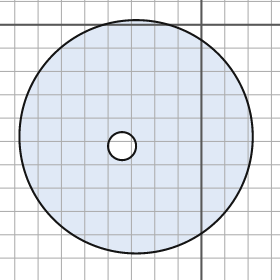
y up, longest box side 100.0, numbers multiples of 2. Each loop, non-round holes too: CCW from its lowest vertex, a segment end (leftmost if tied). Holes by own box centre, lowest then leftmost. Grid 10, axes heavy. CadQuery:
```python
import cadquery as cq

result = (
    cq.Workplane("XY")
    .moveTo(-28.0, -48.0)
    .circle(50.0)
    .moveTo(-34.0, -52.0)
    .circle(6.0)
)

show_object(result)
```